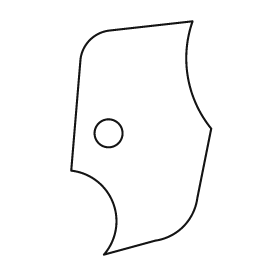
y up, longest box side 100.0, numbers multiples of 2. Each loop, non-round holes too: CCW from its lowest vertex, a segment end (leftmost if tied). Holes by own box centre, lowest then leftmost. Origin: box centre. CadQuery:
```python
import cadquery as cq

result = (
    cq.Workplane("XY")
    .moveTo(-16.0, -50.0)
    .lineTo(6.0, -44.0)
    .threePointArc((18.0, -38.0), (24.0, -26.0))
    .lineTo(30.0, 4.0)
    .threePointArc((20.0, 26.0), (22.0, 50.0))
    .lineTo(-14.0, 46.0)
    .threePointArc((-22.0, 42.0), (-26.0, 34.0))
    .lineTo(-30.0, -14.0)
    .threePointArc((-12.0, -28.0), (-16.0, -50.0))
    .close()
    .moveTo(-14.0, 2.0)
    .circle(6.0)
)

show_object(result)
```